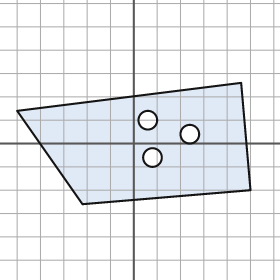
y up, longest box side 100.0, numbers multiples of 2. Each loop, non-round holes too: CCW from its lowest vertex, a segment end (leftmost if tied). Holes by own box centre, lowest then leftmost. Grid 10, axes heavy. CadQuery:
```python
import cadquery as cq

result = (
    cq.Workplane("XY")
    .moveTo(-22.0, -26.0)
    .lineTo(50.0, -20.0)
    .lineTo(46.0, 26.0)
    .lineTo(-50.0, 14.0)
    .close()
    .moveTo(8.0, -6.0)
    .circle(4.0)
    .moveTo(24.0, 4.0)
    .circle(4.0)
    .moveTo(6.0, 10.0)
    .circle(4.0)
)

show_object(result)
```